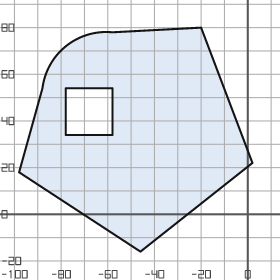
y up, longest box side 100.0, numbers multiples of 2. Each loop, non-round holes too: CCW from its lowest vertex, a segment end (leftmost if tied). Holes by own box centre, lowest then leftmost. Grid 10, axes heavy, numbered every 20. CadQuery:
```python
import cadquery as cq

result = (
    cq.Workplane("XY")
    .moveTo(-46.0, -16.0)
    .lineTo(2.0, 22.0)
    .lineTo(-20.0, 80.0)
    .lineTo(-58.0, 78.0)
    .threePointArc((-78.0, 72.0), (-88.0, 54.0))
    .lineTo(-98.0, 18.0)
    .close()
    .moveTo(-78.0, 34.0)
    .lineTo(-58.0, 34.0)
    .lineTo(-58.0, 54.0)
    .lineTo(-78.0, 54.0)
    .close()
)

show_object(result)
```